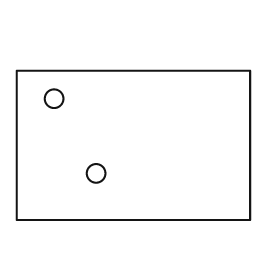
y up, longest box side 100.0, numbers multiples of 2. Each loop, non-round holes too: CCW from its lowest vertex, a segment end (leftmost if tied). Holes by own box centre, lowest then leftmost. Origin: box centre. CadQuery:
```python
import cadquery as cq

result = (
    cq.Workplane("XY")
    .moveTo(-50.0, -32.0)
    .lineTo(50.0, -32.0)
    .lineTo(50.0, 32.0)
    .lineTo(-50.0, 32.0)
    .close()
    .moveTo(-16.0, -12.0)
    .circle(4.0)
    .moveTo(-34.0, 20.0)
    .circle(4.0)
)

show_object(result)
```